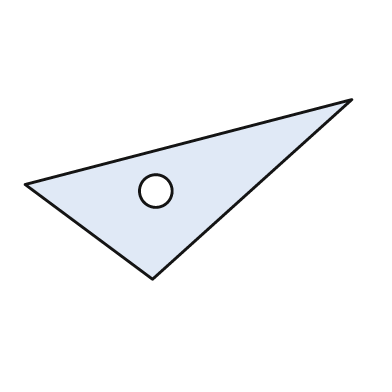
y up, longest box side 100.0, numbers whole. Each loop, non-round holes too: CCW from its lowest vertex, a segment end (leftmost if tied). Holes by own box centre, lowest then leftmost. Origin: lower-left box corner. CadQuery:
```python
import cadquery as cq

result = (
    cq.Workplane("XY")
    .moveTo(39.0, 0.0)
    .lineTo(100.0, 55.0)
    .lineTo(0.0, 29.0)
    .close()
    .moveTo(40.0, 27.0)
    .circle(5.0)
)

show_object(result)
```